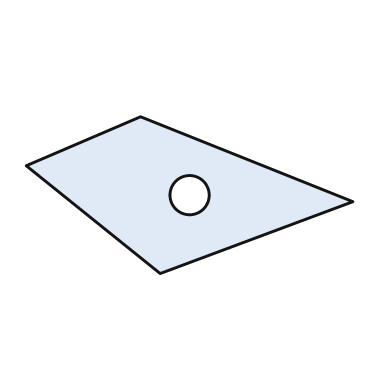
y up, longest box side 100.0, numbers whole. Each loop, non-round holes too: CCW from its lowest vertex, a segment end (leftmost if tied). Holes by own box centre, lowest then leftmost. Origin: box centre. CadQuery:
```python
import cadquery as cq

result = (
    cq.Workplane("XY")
    .moveTo(-9.0, -24.0)
    .lineTo(50.0, -2.0)
    .lineTo(-15.0, 24.0)
    .lineTo(-50.0, 9.0)
    .close()
    .moveTo(0.0, 0.0)
    .circle(6.0)
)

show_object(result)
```